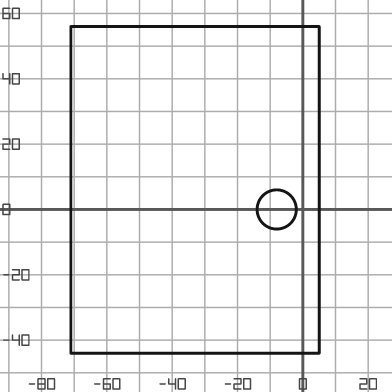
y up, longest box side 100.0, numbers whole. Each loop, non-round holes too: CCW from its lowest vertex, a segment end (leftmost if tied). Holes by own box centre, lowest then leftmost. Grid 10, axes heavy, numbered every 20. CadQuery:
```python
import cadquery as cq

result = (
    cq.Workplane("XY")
    .moveTo(-71.0, -44.0)
    .lineTo(5.0, -44.0)
    .lineTo(5.0, 56.0)
    .lineTo(-71.0, 56.0)
    .close()
    .moveTo(-8.0, 0.0)
    .circle(6.0)
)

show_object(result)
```